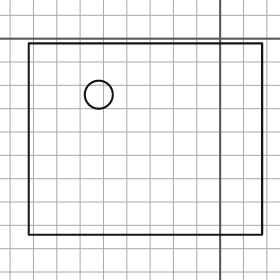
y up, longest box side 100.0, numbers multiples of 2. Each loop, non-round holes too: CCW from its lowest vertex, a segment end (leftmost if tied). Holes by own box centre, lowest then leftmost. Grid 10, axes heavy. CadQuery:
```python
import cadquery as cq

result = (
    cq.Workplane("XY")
    .moveTo(-82.0, -84.0)
    .lineTo(18.0, -84.0)
    .lineTo(18.0, -2.0)
    .lineTo(-82.0, -2.0)
    .close()
    .moveTo(-52.0, -24.0)
    .circle(6.0)
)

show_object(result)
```